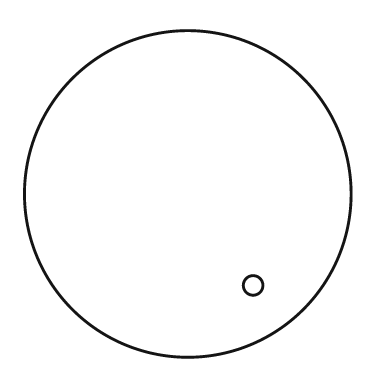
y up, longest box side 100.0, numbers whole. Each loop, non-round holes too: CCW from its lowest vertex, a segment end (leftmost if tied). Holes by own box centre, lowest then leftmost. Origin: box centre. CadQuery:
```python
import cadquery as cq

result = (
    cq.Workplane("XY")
    .moveTo(0.0, 0.0)
    .circle(50.0)
    .moveTo(20.0, -28.0)
    .circle(3.0)
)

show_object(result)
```